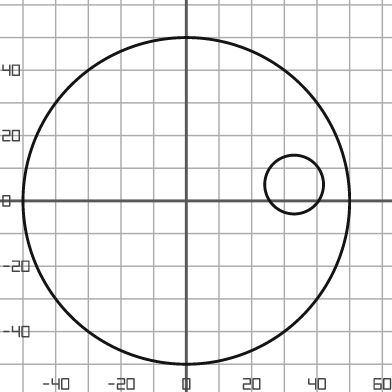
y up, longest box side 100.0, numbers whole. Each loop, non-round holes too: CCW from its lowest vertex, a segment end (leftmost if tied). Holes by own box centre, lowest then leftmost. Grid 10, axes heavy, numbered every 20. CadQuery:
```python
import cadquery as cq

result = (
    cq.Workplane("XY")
    .moveTo(0.0, 0.0)
    .circle(50.0)
    .moveTo(33.0, 5.0)
    .circle(9.0)
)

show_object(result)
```